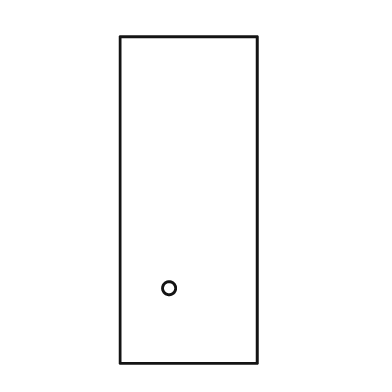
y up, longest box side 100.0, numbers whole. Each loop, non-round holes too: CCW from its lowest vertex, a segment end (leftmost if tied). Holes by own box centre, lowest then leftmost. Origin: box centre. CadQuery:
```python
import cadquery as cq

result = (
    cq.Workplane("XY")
    .moveTo(-21.0, -50.0)
    .lineTo(21.0, -50.0)
    .lineTo(21.0, 50.0)
    .lineTo(-21.0, 50.0)
    .close()
    .moveTo(-6.0, -27.0)
    .circle(2.0)
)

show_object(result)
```